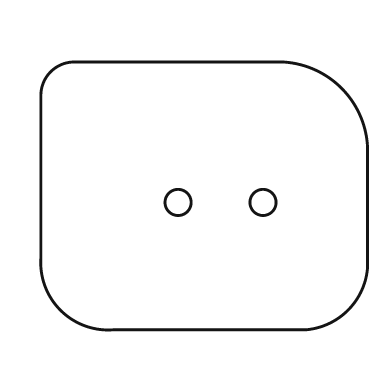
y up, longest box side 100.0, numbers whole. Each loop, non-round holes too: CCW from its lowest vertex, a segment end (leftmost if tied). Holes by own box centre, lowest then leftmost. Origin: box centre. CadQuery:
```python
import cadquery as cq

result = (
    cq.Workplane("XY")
    .moveTo(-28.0, -41.0)
    .lineTo(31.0, -41.0)
    .threePointArc((44.0, -35.0), (50.0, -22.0))
    .lineTo(50.0, 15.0)
    .threePointArc((42.0, 33.0), (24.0, 41.0))
    .lineTo(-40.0, 41.0)
    .threePointArc((-47.0, 38.0), (-50.0, 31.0))
    .lineTo(-50.0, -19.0)
    .threePointArc((-44.0, -35.0), (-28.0, -41.0))
    .close()
    .moveTo(-8.0, -2.0)
    .circle(4.0)
    .moveTo(18.0, -2.0)
    .circle(4.0)
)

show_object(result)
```